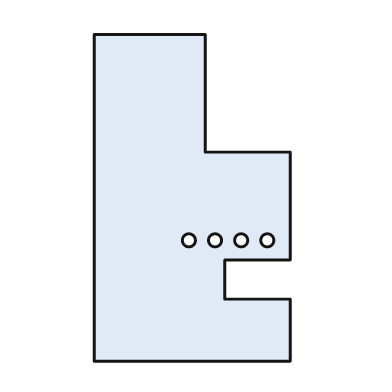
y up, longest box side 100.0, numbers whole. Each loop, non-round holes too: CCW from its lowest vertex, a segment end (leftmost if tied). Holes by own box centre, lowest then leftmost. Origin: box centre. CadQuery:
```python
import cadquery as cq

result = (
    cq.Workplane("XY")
    .moveTo(-30.0, -50.0)
    .lineTo(30.0, -50.0)
    .lineTo(30.0, -31.0)
    .lineTo(10.0, -31.0)
    .lineTo(10.0, -19.0)
    .lineTo(30.0, -19.0)
    .lineTo(30.0, 14.0)
    .lineTo(4.0, 14.0)
    .lineTo(4.0, 50.0)
    .lineTo(-30.0, 50.0)
    .close()
    .moveTo(-1.0, -13.0)
    .circle(2.0)
    .moveTo(7.0, -13.0)
    .circle(2.0)
    .moveTo(15.0, -13.0)
    .circle(2.0)
    .moveTo(23.0, -13.0)
    .circle(2.0)
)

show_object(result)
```